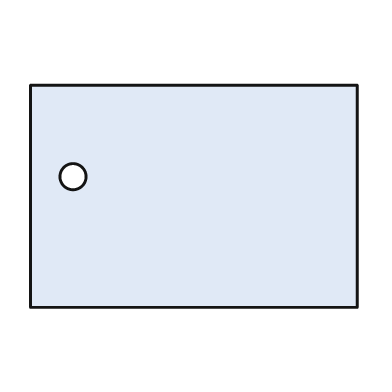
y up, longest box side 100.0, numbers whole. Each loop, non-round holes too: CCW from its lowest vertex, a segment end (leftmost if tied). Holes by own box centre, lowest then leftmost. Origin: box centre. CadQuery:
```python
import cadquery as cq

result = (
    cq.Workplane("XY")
    .moveTo(-50.0, -34.0)
    .lineTo(50.0, -34.0)
    .lineTo(50.0, 34.0)
    .lineTo(-50.0, 34.0)
    .close()
    .moveTo(-37.0, 6.0)
    .circle(4.0)
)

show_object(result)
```